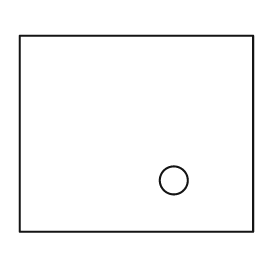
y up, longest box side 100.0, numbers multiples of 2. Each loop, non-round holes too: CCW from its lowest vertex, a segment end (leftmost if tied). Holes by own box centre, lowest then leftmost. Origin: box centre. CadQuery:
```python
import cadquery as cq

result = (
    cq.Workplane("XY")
    .moveTo(-50.0, -42.0)
    .lineTo(50.0, -42.0)
    .lineTo(50.0, 42.0)
    .lineTo(-50.0, 42.0)
    .close()
    .moveTo(16.0, -20.0)
    .circle(6.0)
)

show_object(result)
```